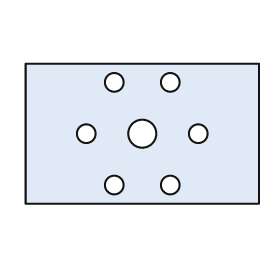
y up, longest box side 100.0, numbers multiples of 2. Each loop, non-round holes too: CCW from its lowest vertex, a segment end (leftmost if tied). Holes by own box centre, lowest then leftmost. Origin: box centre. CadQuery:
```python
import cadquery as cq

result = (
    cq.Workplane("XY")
    .moveTo(-50.0, -30.0)
    .lineTo(50.0, -30.0)
    .lineTo(50.0, 30.0)
    .lineTo(-50.0, 30.0)
    .close()
    .moveTo(-12.0, -22.0)
    .circle(4.0)
    .moveTo(12.0, -22.0)
    .circle(4.0)
    .moveTo(-24.0, 0.0)
    .circle(4.0)
    .moveTo(0.0, 0.0)
    .circle(6.0)
    .moveTo(24.0, 0.0)
    .circle(4.0)
    .moveTo(-12.0, 22.0)
    .circle(4.0)
    .moveTo(12.0, 22.0)
    .circle(4.0)
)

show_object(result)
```